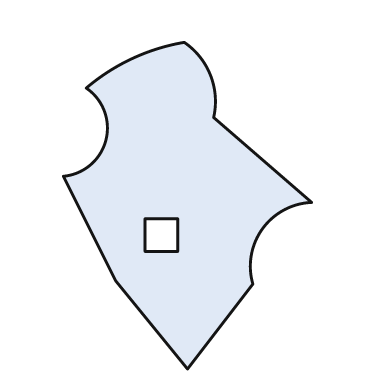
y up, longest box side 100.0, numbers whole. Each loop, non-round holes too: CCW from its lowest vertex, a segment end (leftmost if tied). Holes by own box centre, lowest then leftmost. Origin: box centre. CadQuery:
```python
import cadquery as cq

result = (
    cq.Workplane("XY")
    .moveTo(0.0, -50.0)
    .lineTo(20.0, -24.0)
    .threePointArc((23.0, -7.0), (38.0, 1.0))
    .lineTo(8.0, 27.0)
    .threePointArc((7.0, 40.0), (-1.0, 50.0))
    .threePointArc((-17.0, 45.0), (-31.0, 36.0))
    .threePointArc((-25.0, 20.0), (-38.0, 9.0))
    .lineTo(-22.0, -23.0)
    .close()
    .moveTo(-13.0, -14.0)
    .lineTo(-3.0, -14.0)
    .lineTo(-3.0, -4.0)
    .lineTo(-13.0, -4.0)
    .close()
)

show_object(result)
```